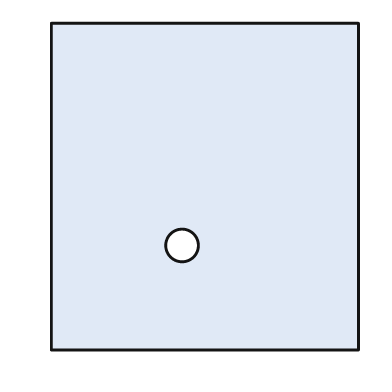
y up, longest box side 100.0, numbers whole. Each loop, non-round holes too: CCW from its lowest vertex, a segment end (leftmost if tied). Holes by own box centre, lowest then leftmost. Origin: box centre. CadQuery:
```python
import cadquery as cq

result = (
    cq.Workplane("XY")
    .moveTo(-47.0, -50.0)
    .lineTo(47.0, -50.0)
    .lineTo(47.0, 50.0)
    .lineTo(-47.0, 50.0)
    .close()
    .moveTo(-7.0, -18.0)
    .circle(5.0)
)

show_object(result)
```